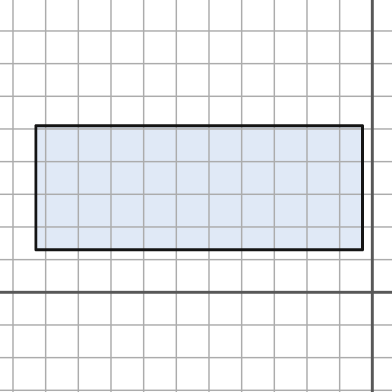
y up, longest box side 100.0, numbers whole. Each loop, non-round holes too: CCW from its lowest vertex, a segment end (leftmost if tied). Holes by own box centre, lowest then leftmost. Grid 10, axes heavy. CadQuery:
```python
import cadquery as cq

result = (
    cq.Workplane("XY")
    .moveTo(-103.0, 13.0)
    .lineTo(-3.0, 13.0)
    .lineTo(-3.0, 51.0)
    .lineTo(-103.0, 51.0)
    .close()
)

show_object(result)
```